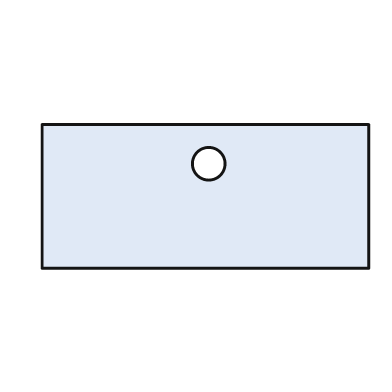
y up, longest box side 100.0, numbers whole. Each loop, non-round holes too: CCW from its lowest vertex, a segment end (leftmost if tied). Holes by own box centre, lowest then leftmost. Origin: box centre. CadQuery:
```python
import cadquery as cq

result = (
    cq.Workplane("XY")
    .moveTo(-50.0, -22.0)
    .lineTo(50.0, -22.0)
    .lineTo(50.0, 22.0)
    .lineTo(-50.0, 22.0)
    .close()
    .moveTo(1.0, 10.0)
    .circle(5.0)
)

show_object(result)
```